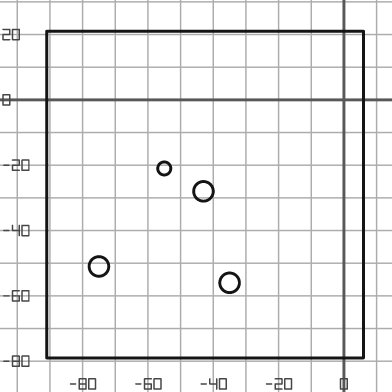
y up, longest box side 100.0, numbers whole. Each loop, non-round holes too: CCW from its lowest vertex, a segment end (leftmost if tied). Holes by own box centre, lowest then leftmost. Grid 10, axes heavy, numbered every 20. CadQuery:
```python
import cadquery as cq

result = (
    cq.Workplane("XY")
    .moveTo(-91.0, -79.0)
    .lineTo(6.0, -79.0)
    .lineTo(6.0, 21.0)
    .lineTo(-91.0, 21.0)
    .close()
    .moveTo(-35.0, -56.0)
    .circle(3.0)
    .moveTo(-75.0, -51.0)
    .circle(3.0)
    .moveTo(-43.0, -28.0)
    .circle(3.0)
    .moveTo(-55.0, -21.0)
    .circle(2.0)
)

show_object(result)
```